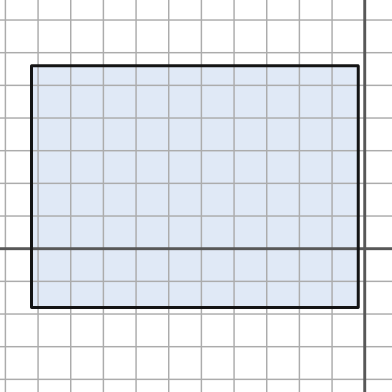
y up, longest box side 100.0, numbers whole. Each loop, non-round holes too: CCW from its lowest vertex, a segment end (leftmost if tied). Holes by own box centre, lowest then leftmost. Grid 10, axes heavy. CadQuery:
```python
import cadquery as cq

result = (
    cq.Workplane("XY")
    .moveTo(-102.0, -18.0)
    .lineTo(-2.0, -18.0)
    .lineTo(-2.0, 56.0)
    .lineTo(-102.0, 56.0)
    .close()
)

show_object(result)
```